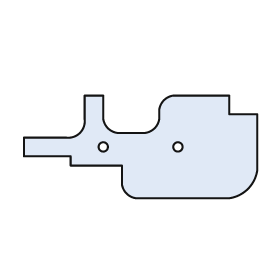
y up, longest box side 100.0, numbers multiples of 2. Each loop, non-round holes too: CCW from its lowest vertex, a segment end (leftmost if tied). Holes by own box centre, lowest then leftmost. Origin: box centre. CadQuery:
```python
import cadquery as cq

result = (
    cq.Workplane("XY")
    .moveTo(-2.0, -22.0)
    .lineTo(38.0, -22.0)
    .threePointArc((46.0, -18.0), (50.0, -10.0))
    .lineTo(50.0, 14.0)
    .lineTo(38.0, 14.0)
    .lineTo(38.0, 22.0)
    .lineTo(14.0, 22.0)
    .threePointArc((10.0, 20.0), (8.0, 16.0))
    .lineTo(8.0, 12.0)
    .threePointArc((6.0, 8.0), (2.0, 6.0))
    .lineTo(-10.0, 6.0)
    .threePointArc((-14.0, 8.0), (-16.0, 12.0))
    .lineTo(-16.0, 22.0)
    .lineTo(-24.0, 22.0)
    .lineTo(-24.0, 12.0)
    .threePointArc((-26.0, 6.0), (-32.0, 4.0))
    .lineTo(-50.0, 4.0)
    .lineTo(-50.0, -4.0)
    .lineTo(-30.0, -4.0)
    .lineTo(-30.0, -8.0)
    .lineTo(-8.0, -8.0)
    .lineTo(-8.0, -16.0)
    .threePointArc((-6.0, -20.0), (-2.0, -22.0))
    .close()
    .moveTo(-16.0, 0.0)
    .circle(2.0)
    .moveTo(16.0, 0.0)
    .circle(2.0)
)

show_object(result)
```